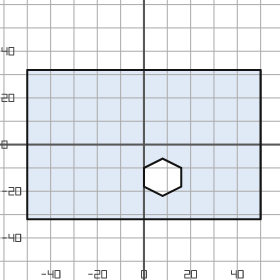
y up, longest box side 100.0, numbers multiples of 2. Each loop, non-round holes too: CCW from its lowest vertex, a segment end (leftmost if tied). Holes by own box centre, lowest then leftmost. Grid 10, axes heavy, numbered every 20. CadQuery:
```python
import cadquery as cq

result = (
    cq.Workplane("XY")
    .moveTo(-50.0, -32.0)
    .lineTo(50.0, -32.0)
    .lineTo(50.0, 32.0)
    .lineTo(-50.0, 32.0)
    .close()
    .moveTo(8.0, -22.0)
    .lineTo(16.0, -18.0)
    .lineTo(16.0, -10.0)
    .lineTo(8.0, -6.0)
    .lineTo(0.0, -10.0)
    .lineTo(0.0, -18.0)
    .close()
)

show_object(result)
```